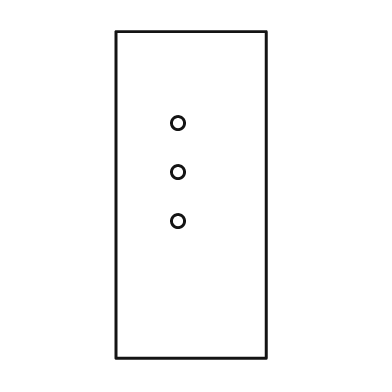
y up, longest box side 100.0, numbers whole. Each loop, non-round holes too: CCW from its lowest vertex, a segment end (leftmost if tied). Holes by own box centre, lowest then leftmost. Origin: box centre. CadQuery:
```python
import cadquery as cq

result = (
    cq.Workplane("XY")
    .moveTo(-23.0, -50.0)
    .lineTo(23.0, -50.0)
    .lineTo(23.0, 50.0)
    .lineTo(-23.0, 50.0)
    .close()
    .moveTo(-4.0, -8.0)
    .circle(2.0)
    .moveTo(-4.0, 7.0)
    .circle(2.0)
    .moveTo(-4.0, 22.0)
    .circle(2.0)
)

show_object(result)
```